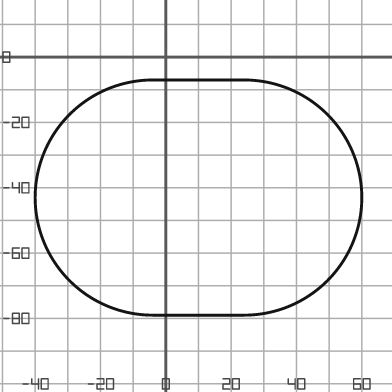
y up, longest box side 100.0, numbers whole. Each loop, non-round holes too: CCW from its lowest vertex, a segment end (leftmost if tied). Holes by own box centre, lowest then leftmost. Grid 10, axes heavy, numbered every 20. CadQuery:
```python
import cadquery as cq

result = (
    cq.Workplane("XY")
    .moveTo(-4.0, -79.0)
    .lineTo(24.0, -79.0)
    .threePointArc((60.0, -43.0), (24.0, -7.0))
    .lineTo(-4.0, -7.0)
    .threePointArc((-40.0, -43.0), (-4.0, -79.0))
    .close()
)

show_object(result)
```